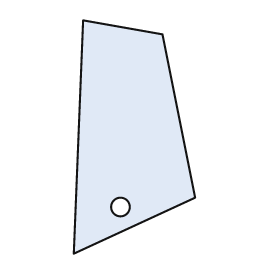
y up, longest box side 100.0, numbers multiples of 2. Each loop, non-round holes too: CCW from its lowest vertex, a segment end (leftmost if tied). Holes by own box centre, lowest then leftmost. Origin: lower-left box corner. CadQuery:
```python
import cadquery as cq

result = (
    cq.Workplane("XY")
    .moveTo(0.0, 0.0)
    .lineTo(52.0, 24.0)
    .lineTo(38.0, 94.0)
    .lineTo(4.0, 100.0)
    .close()
    .moveTo(20.0, 20.0)
    .circle(4.0)
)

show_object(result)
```